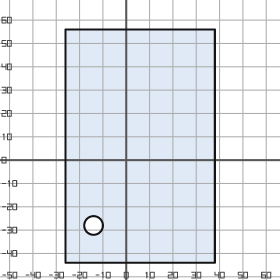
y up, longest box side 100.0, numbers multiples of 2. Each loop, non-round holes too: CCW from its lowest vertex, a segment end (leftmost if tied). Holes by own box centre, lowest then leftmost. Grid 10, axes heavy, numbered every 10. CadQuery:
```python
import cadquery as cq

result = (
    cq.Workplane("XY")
    .moveTo(-26.0, -44.0)
    .lineTo(38.0, -44.0)
    .lineTo(38.0, 56.0)
    .lineTo(-26.0, 56.0)
    .close()
    .moveTo(-14.0, -28.0)
    .circle(4.0)
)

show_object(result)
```